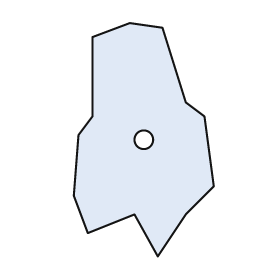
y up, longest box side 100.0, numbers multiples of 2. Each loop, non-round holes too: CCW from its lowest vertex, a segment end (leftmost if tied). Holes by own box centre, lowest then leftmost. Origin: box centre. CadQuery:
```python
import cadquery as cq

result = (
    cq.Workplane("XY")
    .moveTo(6.0, -50.0)
    .lineTo(18.0, -32.0)
    .lineTo(30.0, -20.0)
    .lineTo(26.0, 10.0)
    .lineTo(18.0, 16.0)
    .lineTo(8.0, 48.0)
    .lineTo(-6.0, 50.0)
    .lineTo(-22.0, 44.0)
    .lineTo(-22.0, 10.0)
    .lineTo(-28.0, 2.0)
    .lineTo(-30.0, -24.0)
    .lineTo(-24.0, -40.0)
    .lineTo(-4.0, -32.0)
    .close()
    .moveTo(0.0, 0.0)
    .circle(4.0)
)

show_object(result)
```